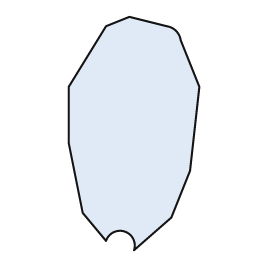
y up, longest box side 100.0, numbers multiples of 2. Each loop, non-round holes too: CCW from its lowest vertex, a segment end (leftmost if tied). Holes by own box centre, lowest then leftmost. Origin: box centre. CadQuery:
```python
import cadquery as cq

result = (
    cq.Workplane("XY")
    .moveTo(0.0, -50.0)
    .lineTo(16.0, -36.0)
    .lineTo(24.0, -16.0)
    .lineTo(28.0, 20.0)
    .lineTo(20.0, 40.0)
    .threePointArc((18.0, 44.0), (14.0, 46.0))
    .lineTo(-2.0, 50.0)
    .lineTo(-12.0, 46.0)
    .lineTo(-28.0, 20.0)
    .lineTo(-28.0, -4.0)
    .lineTo(-22.0, -34.0)
    .lineTo(-12.0, -46.0)
    .threePointArc((-4.0, -42.0), (0.0, -50.0))
    .close()
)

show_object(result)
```